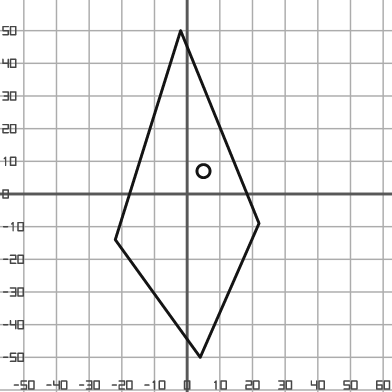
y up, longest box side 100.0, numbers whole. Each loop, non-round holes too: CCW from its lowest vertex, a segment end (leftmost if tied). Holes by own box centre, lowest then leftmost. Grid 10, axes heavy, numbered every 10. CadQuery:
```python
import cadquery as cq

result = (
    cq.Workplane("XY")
    .moveTo(4.0, -50.0)
    .lineTo(22.0, -9.0)
    .lineTo(-2.0, 50.0)
    .lineTo(-22.0, -14.0)
    .close()
    .moveTo(5.0, 7.0)
    .circle(2.0)
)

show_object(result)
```